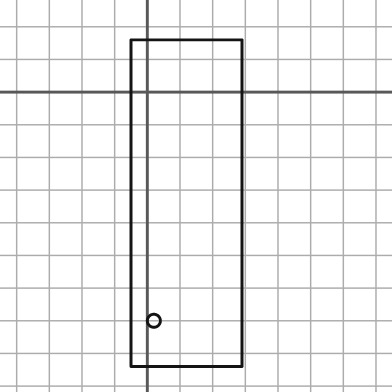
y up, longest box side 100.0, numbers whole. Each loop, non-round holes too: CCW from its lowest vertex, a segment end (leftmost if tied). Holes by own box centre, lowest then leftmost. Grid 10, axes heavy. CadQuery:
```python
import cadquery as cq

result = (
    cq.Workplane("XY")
    .moveTo(-5.0, -84.0)
    .lineTo(29.0, -84.0)
    .lineTo(29.0, 16.0)
    .lineTo(-5.0, 16.0)
    .close()
    .moveTo(2.0, -70.0)
    .circle(2.0)
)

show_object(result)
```